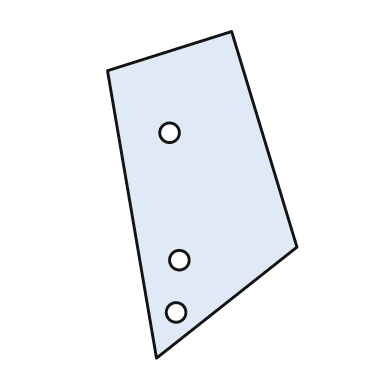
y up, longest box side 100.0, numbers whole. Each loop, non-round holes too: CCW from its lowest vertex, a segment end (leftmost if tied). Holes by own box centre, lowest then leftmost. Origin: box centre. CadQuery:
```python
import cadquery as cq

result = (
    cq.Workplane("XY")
    .moveTo(-14.0, -50.0)
    .lineTo(29.0, -16.0)
    .lineTo(9.0, 50.0)
    .lineTo(-29.0, 38.0)
    .close()
    .moveTo(-8.0, -36.0)
    .circle(3.0)
    .moveTo(-7.0, -20.0)
    .circle(3.0)
    .moveTo(-10.0, 19.0)
    .circle(3.0)
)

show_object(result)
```